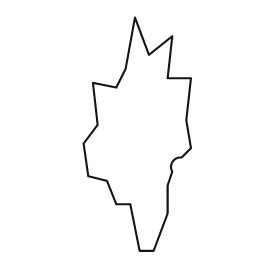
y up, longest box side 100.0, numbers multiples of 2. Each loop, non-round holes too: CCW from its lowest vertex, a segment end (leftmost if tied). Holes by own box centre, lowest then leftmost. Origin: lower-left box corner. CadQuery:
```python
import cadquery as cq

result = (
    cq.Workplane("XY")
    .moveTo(24.0, 0.0)
    .lineTo(30.0, 0.0)
    .lineTo(36.0, 16.0)
    .lineTo(36.0, 28.0)
    .lineTo(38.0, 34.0)
    .threePointArc((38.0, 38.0), (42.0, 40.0))
    .lineTo(46.0, 44.0)
    .lineTo(44.0, 56.0)
    .lineTo(46.0, 74.0)
    .lineTo(36.0, 74.0)
    .lineTo(38.0, 92.0)
    .lineTo(28.0, 84.0)
    .lineTo(22.0, 100.0)
    .lineTo(18.0, 78.0)
    .lineTo(14.0, 70.0)
    .lineTo(4.0, 72.0)
    .lineTo(6.0, 54.0)
    .lineTo(0.0, 46.0)
    .lineTo(2.0, 32.0)
    .lineTo(10.0, 30.0)
    .lineTo(14.0, 20.0)
    .lineTo(20.0, 20.0)
    .close()
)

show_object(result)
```